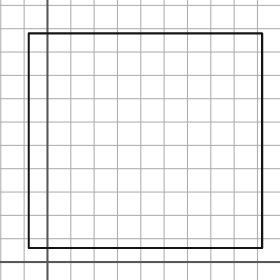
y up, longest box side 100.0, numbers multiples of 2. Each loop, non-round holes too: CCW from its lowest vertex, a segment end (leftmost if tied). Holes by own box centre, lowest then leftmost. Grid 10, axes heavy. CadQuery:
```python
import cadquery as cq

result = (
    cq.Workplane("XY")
    .moveTo(-8.0, 6.0)
    .lineTo(92.0, 6.0)
    .lineTo(92.0, 98.0)
    .lineTo(-8.0, 98.0)
    .close()
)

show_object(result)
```